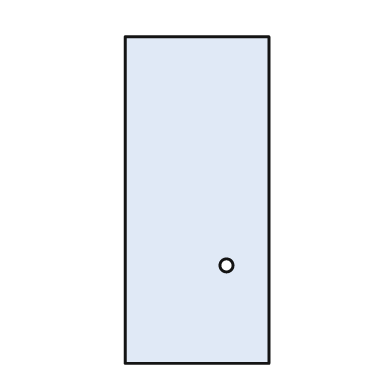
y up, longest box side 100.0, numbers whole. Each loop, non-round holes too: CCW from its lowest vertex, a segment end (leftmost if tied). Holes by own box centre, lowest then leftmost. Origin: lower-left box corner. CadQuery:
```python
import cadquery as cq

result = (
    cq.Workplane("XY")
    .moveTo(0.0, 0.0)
    .lineTo(44.0, 0.0)
    .lineTo(44.0, 100.0)
    .lineTo(0.0, 100.0)
    .close()
    .moveTo(31.0, 30.0)
    .circle(2.0)
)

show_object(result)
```